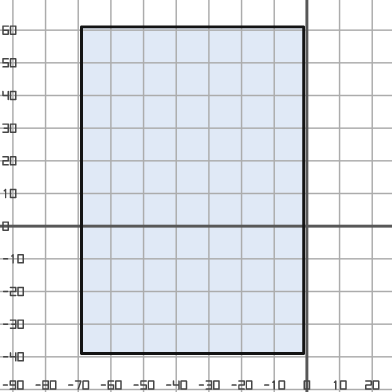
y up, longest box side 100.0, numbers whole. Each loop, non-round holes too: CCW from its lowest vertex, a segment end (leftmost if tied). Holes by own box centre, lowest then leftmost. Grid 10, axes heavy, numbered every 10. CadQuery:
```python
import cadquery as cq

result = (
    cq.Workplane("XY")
    .moveTo(-69.0, -39.0)
    .lineTo(-1.0, -39.0)
    .lineTo(-1.0, 61.0)
    .lineTo(-69.0, 61.0)
    .close()
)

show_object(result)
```